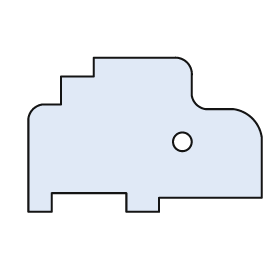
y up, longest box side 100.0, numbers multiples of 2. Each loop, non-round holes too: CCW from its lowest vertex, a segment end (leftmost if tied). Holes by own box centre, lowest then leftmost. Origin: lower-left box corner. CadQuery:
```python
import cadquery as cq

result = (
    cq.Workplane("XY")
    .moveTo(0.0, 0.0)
    .lineTo(10.0, 0.0)
    .lineTo(10.0, 8.0)
    .lineTo(42.0, 8.0)
    .lineTo(42.0, 0.0)
    .lineTo(56.0, 0.0)
    .lineTo(56.0, 6.0)
    .lineTo(100.0, 6.0)
    .lineTo(100.0, 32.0)
    .threePointArc((96.0, 40.0), (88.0, 44.0))
    .lineTo(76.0, 44.0)
    .threePointArc((72.0, 46.0), (70.0, 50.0))
    .lineTo(70.0, 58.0)
    .threePointArc((68.0, 64.0), (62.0, 66.0))
    .lineTo(28.0, 66.0)
    .lineTo(28.0, 58.0)
    .lineTo(14.0, 58.0)
    .lineTo(14.0, 46.0)
    .lineTo(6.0, 46.0)
    .threePointArc((2.0, 44.0), (0.0, 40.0))
    .close()
    .moveTo(66.0, 30.0)
    .circle(4.0)
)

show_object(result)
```